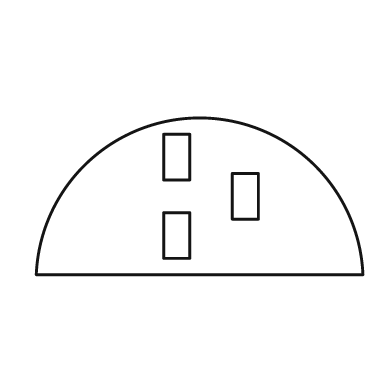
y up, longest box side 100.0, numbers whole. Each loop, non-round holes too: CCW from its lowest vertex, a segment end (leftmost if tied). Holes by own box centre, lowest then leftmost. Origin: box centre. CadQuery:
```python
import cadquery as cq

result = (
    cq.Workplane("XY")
    .moveTo(-50.0, -24.0)
    .lineTo(50.0, -24.0)
    .threePointArc((0.0, 24.0), (-50.0, -24.0))
    .close()
    .moveTo(-11.0, -19.0)
    .lineTo(-3.0, -19.0)
    .lineTo(-3.0, -5.0)
    .lineTo(-11.0, -5.0)
    .close()
    .moveTo(10.0, -7.0)
    .lineTo(18.0, -7.0)
    .lineTo(18.0, 7.0)
    .lineTo(10.0, 7.0)
    .close()
    .moveTo(-11.0, 5.0)
    .lineTo(-3.0, 5.0)
    .lineTo(-3.0, 19.0)
    .lineTo(-11.0, 19.0)
    .close()
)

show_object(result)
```